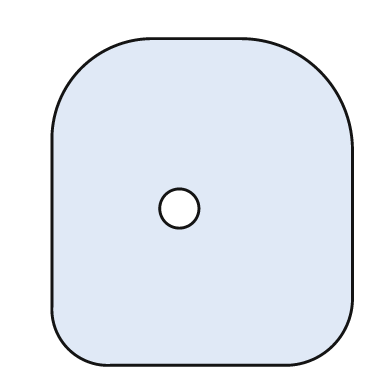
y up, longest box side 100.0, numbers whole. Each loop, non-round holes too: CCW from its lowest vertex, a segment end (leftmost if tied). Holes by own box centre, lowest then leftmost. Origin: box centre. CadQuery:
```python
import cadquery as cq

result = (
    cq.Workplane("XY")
    .moveTo(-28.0, -50.0)
    .lineTo(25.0, -50.0)
    .threePointArc((40.0, -44.0), (46.0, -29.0))
    .lineTo(46.0, 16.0)
    .threePointArc((36.0, 40.0), (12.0, 50.0))
    .lineTo(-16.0, 50.0)
    .threePointArc((-37.0, 41.0), (-46.0, 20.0))
    .lineTo(-46.0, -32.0)
    .threePointArc((-41.0, -45.0), (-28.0, -50.0))
    .close()
    .moveTo(-7.0, -2.0)
    .circle(6.0)
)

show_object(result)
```